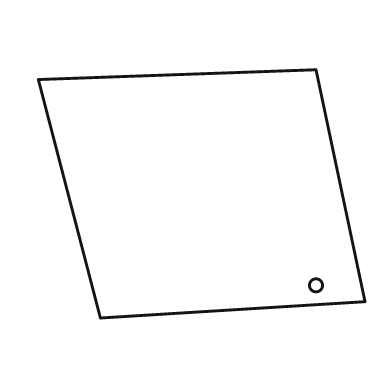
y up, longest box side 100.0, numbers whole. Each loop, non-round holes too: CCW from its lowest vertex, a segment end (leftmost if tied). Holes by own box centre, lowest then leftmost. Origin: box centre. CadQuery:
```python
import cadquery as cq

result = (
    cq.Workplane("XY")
    .moveTo(-31.0, -38.0)
    .lineTo(50.0, -33.0)
    .lineTo(35.0, 38.0)
    .lineTo(-50.0, 35.0)
    .close()
    .moveTo(35.0, -28.0)
    .circle(2.0)
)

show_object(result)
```